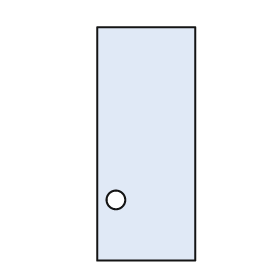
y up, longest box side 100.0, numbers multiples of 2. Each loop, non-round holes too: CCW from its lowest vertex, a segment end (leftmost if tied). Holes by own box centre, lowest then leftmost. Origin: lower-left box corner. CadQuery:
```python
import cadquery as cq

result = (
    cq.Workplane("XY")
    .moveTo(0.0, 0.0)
    .lineTo(42.0, 0.0)
    .lineTo(42.0, 100.0)
    .lineTo(0.0, 100.0)
    .close()
    .moveTo(8.0, 26.0)
    .circle(4.0)
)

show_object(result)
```